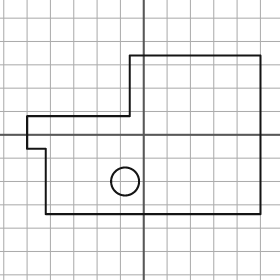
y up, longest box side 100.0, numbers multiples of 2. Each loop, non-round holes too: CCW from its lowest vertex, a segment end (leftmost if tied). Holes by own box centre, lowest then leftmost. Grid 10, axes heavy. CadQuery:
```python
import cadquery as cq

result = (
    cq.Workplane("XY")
    .moveTo(-42.0, -34.0)
    .lineTo(50.0, -34.0)
    .lineTo(50.0, 34.0)
    .lineTo(-6.0, 34.0)
    .lineTo(-6.0, 8.0)
    .lineTo(-50.0, 8.0)
    .lineTo(-50.0, -6.0)
    .lineTo(-42.0, -6.0)
    .close()
    .moveTo(-8.0, -20.0)
    .circle(6.0)
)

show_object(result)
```